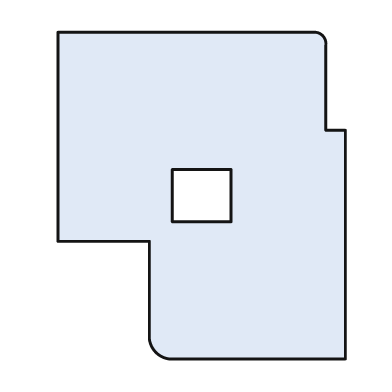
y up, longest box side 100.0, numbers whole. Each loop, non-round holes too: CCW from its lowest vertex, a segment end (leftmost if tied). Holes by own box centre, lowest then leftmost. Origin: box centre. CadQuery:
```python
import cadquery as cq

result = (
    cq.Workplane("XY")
    .moveTo(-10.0, -50.0)
    .lineTo(44.0, -50.0)
    .lineTo(44.0, 20.0)
    .lineTo(38.0, 20.0)
    .lineTo(38.0, 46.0)
    .threePointArc((37.0, 49.0), (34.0, 50.0))
    .lineTo(-44.0, 50.0)
    .lineTo(-44.0, -14.0)
    .lineTo(-16.0, -14.0)
    .lineTo(-16.0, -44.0)
    .threePointArc((-14.0, -48.0), (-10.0, -50.0))
    .close()
    .moveTo(-9.0, -8.0)
    .lineTo(9.0, -8.0)
    .lineTo(9.0, 8.0)
    .lineTo(-9.0, 8.0)
    .close()
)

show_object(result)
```